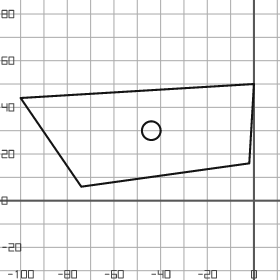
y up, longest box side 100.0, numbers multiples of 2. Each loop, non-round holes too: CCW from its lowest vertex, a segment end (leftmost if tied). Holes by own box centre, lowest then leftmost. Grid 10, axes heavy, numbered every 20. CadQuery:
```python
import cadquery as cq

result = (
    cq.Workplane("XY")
    .moveTo(-74.0, 6.0)
    .lineTo(-2.0, 16.0)
    .lineTo(0.0, 50.0)
    .lineTo(-100.0, 44.0)
    .close()
    .moveTo(-44.0, 30.0)
    .circle(4.0)
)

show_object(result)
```